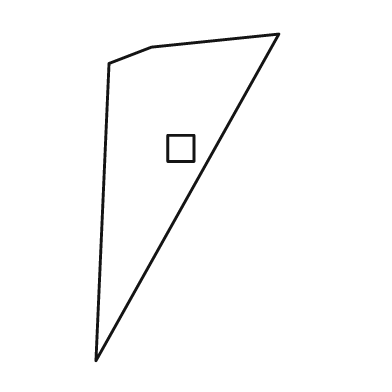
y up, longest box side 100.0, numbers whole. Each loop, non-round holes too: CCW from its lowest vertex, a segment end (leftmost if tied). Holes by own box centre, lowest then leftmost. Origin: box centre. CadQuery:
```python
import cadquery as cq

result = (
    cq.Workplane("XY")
    .moveTo(-28.0, -50.0)
    .lineTo(28.0, 50.0)
    .lineTo(-11.0, 46.0)
    .lineTo(-24.0, 41.0)
    .close()
    .moveTo(-6.0, 11.0)
    .lineTo(2.0, 11.0)
    .lineTo(2.0, 19.0)
    .lineTo(-6.0, 19.0)
    .close()
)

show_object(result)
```